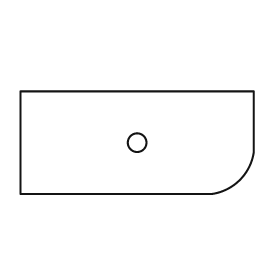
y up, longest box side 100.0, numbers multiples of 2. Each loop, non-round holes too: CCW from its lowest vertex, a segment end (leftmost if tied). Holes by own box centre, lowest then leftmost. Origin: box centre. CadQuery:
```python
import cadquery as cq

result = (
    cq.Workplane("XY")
    .moveTo(-50.0, -22.0)
    .lineTo(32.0, -22.0)
    .threePointArc((44.0, -16.0), (50.0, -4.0))
    .lineTo(50.0, 22.0)
    .lineTo(-50.0, 22.0)
    .close()
    .moveTo(0.0, 0.0)
    .circle(4.0)
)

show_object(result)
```